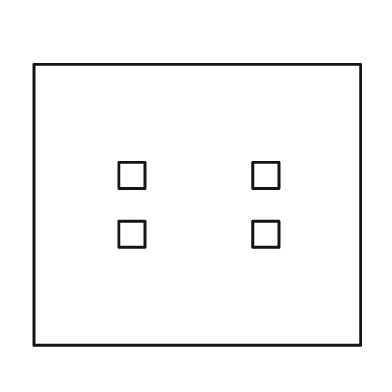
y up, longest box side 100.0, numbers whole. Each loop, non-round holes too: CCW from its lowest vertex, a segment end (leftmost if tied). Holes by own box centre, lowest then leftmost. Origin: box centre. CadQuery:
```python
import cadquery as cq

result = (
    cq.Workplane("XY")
    .moveTo(-50.0, -43.0)
    .lineTo(50.0, -43.0)
    .lineTo(50.0, 43.0)
    .lineTo(-50.0, 43.0)
    .close()
    .moveTo(-24.0, -13.0)
    .lineTo(-16.0, -13.0)
    .lineTo(-16.0, -5.0)
    .lineTo(-24.0, -5.0)
    .close()
    .moveTo(17.0, -13.0)
    .lineTo(25.0, -13.0)
    .lineTo(25.0, -5.0)
    .lineTo(17.0, -5.0)
    .close()
    .moveTo(-24.0, 5.0)
    .lineTo(-16.0, 5.0)
    .lineTo(-16.0, 13.0)
    .lineTo(-24.0, 13.0)
    .close()
    .moveTo(17.0, 5.0)
    .lineTo(25.0, 5.0)
    .lineTo(25.0, 13.0)
    .lineTo(17.0, 13.0)
    .close()
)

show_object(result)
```